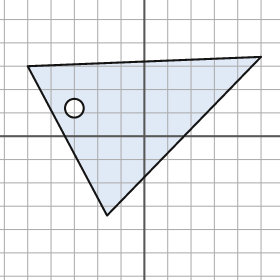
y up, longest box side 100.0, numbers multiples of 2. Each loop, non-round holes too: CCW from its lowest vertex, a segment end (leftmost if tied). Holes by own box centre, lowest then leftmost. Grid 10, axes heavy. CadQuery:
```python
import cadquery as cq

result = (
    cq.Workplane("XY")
    .moveTo(-16.0, -34.0)
    .lineTo(50.0, 34.0)
    .lineTo(-50.0, 30.0)
    .close()
    .moveTo(-30.0, 12.0)
    .circle(4.0)
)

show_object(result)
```